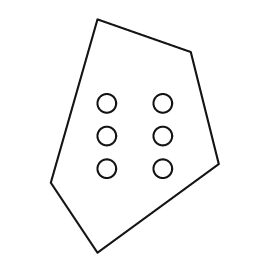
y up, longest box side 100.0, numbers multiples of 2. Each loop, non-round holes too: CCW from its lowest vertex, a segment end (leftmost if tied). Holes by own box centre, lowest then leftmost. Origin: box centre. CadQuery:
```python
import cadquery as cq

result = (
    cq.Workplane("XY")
    .moveTo(-16.0, -50.0)
    .lineTo(36.0, -12.0)
    .lineTo(24.0, 36.0)
    .lineTo(-16.0, 50.0)
    .lineTo(-36.0, -20.0)
    .close()
    .moveTo(-12.0, -14.0)
    .circle(4.0)
    .moveTo(12.0, -14.0)
    .circle(4.0)
    .moveTo(-12.0, 0.0)
    .circle(4.0)
    .moveTo(12.0, 0.0)
    .circle(4.0)
    .moveTo(-12.0, 14.0)
    .circle(4.0)
    .moveTo(12.0, 14.0)
    .circle(4.0)
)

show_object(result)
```